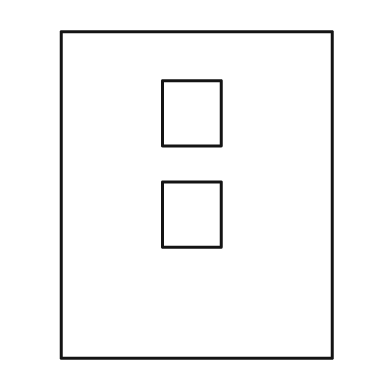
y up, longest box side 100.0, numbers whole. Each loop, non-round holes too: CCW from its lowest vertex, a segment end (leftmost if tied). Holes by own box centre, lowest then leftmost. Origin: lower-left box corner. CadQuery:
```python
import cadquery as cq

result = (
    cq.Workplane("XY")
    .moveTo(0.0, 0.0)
    .lineTo(83.0, 0.0)
    .lineTo(83.0, 100.0)
    .lineTo(0.0, 100.0)
    .close()
    .moveTo(31.0, 34.0)
    .lineTo(49.0, 34.0)
    .lineTo(49.0, 54.0)
    .lineTo(31.0, 54.0)
    .close()
    .moveTo(31.0, 65.0)
    .lineTo(49.0, 65.0)
    .lineTo(49.0, 85.0)
    .lineTo(31.0, 85.0)
    .close()
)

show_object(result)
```